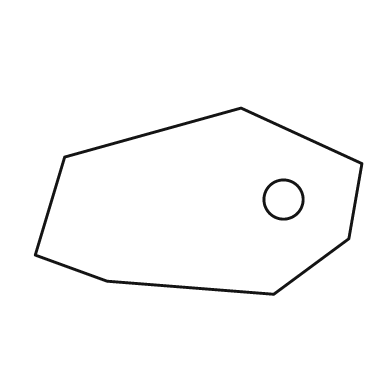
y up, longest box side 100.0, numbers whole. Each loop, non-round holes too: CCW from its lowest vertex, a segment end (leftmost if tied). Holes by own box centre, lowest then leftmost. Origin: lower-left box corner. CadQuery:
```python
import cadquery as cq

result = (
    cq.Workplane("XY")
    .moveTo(73.0, 0.0)
    .lineTo(96.0, 17.0)
    .lineTo(100.0, 40.0)
    .lineTo(63.0, 57.0)
    .lineTo(9.0, 42.0)
    .lineTo(0.0, 12.0)
    .lineTo(22.0, 4.0)
    .close()
    .moveTo(76.0, 29.0)
    .circle(6.0)
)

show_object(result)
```